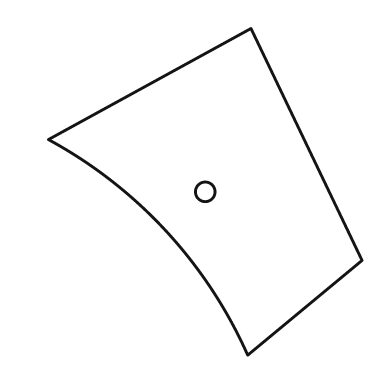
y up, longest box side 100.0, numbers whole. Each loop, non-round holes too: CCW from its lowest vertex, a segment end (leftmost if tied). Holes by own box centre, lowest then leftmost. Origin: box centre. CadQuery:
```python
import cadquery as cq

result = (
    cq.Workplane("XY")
    .moveTo(13.0, -50.0)
    .lineTo(48.0, -21.0)
    .lineTo(14.0, 50.0)
    .lineTo(-48.0, 16.0)
    .threePointArc((-12.0, -12.0), (13.0, -50.0))
    .close()
    .moveTo(0.0, 0.0)
    .circle(3.0)
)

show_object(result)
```